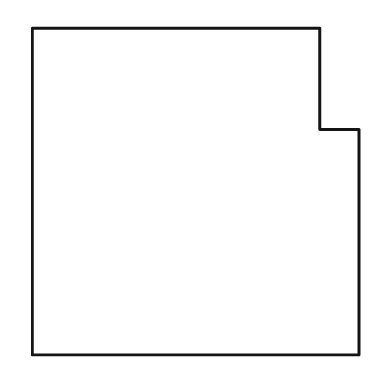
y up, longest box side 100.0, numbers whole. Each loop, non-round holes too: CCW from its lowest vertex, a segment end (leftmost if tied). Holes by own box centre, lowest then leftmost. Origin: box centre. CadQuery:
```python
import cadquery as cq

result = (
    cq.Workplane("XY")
    .moveTo(-50.0, -50.0)
    .lineTo(50.0, -50.0)
    .lineTo(50.0, 19.0)
    .lineTo(38.0, 19.0)
    .lineTo(38.0, 50.0)
    .lineTo(-50.0, 50.0)
    .close()
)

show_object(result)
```